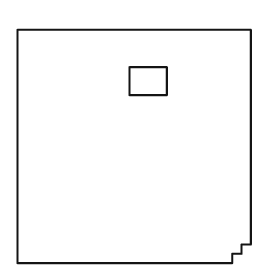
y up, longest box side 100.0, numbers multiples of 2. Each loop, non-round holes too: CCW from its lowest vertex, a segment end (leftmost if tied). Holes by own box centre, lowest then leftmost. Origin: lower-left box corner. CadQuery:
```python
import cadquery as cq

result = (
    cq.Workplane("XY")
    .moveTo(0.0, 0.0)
    .lineTo(92.0, 0.0)
    .lineTo(92.0, 4.0)
    .lineTo(96.0, 4.0)
    .lineTo(96.0, 8.0)
    .lineTo(100.0, 8.0)
    .lineTo(100.0, 100.0)
    .lineTo(0.0, 100.0)
    .close()
    .moveTo(48.0, 72.0)
    .lineTo(64.0, 72.0)
    .lineTo(64.0, 84.0)
    .lineTo(48.0, 84.0)
    .close()
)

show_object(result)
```